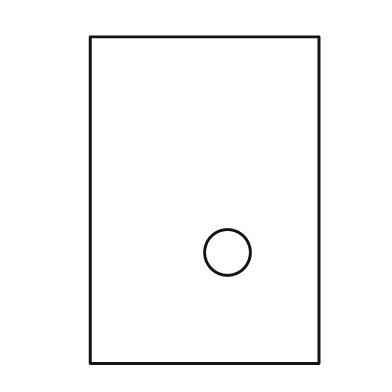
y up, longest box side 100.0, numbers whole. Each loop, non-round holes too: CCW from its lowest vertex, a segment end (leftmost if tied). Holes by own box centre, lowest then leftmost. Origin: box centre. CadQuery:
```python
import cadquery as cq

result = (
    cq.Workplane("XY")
    .moveTo(-35.0, -50.0)
    .lineTo(35.0, -50.0)
    .lineTo(35.0, 50.0)
    .lineTo(-35.0, 50.0)
    .close()
    .moveTo(7.0, -16.0)
    .circle(7.0)
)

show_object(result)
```